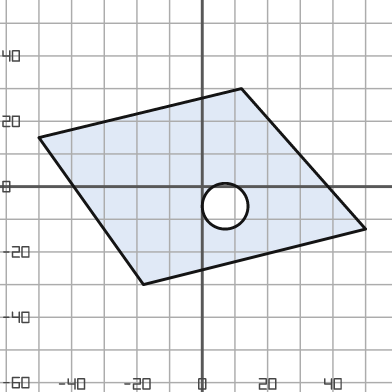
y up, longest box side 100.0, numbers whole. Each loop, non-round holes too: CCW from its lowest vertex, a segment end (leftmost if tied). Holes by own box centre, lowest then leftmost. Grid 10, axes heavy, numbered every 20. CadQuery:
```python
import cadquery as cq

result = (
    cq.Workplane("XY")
    .moveTo(-18.0, -30.0)
    .lineTo(50.0, -13.0)
    .lineTo(12.0, 30.0)
    .lineTo(-50.0, 15.0)
    .close()
    .moveTo(7.0, -6.0)
    .circle(7.0)
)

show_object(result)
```